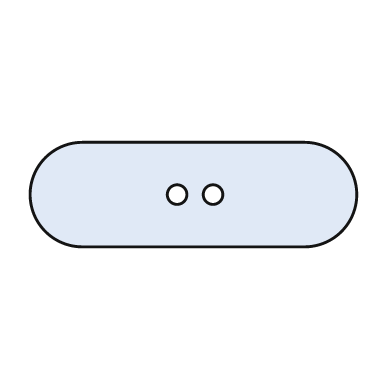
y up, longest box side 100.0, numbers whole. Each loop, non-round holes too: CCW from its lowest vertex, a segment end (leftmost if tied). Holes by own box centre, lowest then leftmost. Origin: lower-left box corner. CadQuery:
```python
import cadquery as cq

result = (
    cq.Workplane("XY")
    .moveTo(16.0, 0.0)
    .lineTo(84.0, 0.0)
    .threePointArc((100.0, 16.0), (84.0, 32.0))
    .lineTo(16.0, 32.0)
    .threePointArc((0.0, 16.0), (16.0, 0.0))
    .close()
    .moveTo(45.0, 16.0)
    .circle(3.0)
    .moveTo(56.0, 16.0)
    .circle(3.0)
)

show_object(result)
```